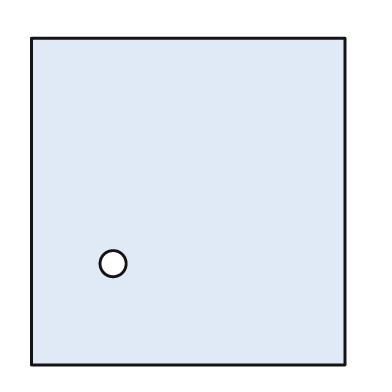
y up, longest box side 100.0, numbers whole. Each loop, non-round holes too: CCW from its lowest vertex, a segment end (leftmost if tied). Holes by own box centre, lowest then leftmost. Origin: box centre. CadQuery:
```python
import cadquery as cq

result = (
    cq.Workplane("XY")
    .moveTo(-48.0, -50.0)
    .lineTo(48.0, -50.0)
    .lineTo(48.0, 50.0)
    .lineTo(-48.0, 50.0)
    .close()
    .moveTo(-23.0, -19.0)
    .circle(4.0)
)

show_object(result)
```